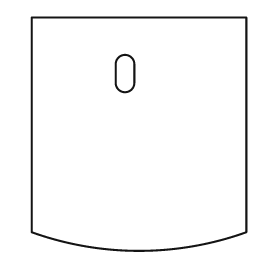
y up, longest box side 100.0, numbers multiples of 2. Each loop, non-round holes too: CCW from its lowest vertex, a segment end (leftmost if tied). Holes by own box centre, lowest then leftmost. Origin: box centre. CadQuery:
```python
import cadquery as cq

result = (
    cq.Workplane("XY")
    .moveTo(-46.0, -42.0)
    .threePointArc((0.0, -50.0), (46.0, -42.0))
    .lineTo(46.0, 50.0)
    .lineTo(-46.0, 50.0)
    .close()
    .moveTo(-10.0, 22.0)
    .threePointArc((-6.0, 18.0), (-2.0, 22.0))
    .lineTo(-2.0, 30.0)
    .threePointArc((-6.0, 34.0), (-10.0, 30.0))
    .close()
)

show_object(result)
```